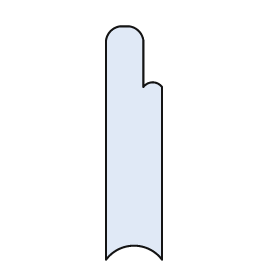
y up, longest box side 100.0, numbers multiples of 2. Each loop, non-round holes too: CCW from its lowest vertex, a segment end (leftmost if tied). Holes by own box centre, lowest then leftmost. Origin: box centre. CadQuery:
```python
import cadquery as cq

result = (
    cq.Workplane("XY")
    .moveTo(-12.0, -50.0)
    .threePointArc((0.0, -44.0), (12.0, -50.0))
    .lineTo(12.0, 24.0)
    .threePointArc((8.0, 26.0), (4.0, 24.0))
    .lineTo(4.0, 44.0)
    .threePointArc((2.0, 48.0), (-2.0, 50.0))
    .lineTo(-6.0, 50.0)
    .threePointArc((-10.0, 48.0), (-12.0, 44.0))
    .close()
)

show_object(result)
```